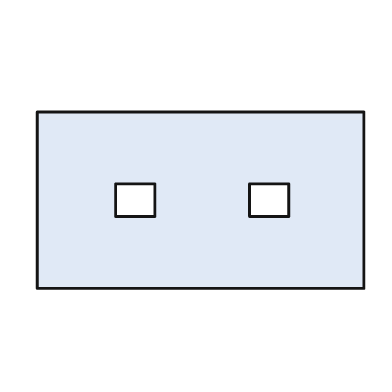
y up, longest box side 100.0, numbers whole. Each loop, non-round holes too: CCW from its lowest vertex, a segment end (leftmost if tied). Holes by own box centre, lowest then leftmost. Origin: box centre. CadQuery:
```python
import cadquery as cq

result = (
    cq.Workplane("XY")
    .moveTo(-50.0, -27.0)
    .lineTo(50.0, -27.0)
    .lineTo(50.0, 27.0)
    .lineTo(-50.0, 27.0)
    .close()
    .moveTo(-26.0, -5.0)
    .lineTo(-14.0, -5.0)
    .lineTo(-14.0, 5.0)
    .lineTo(-26.0, 5.0)
    .close()
    .moveTo(15.0, -5.0)
    .lineTo(27.0, -5.0)
    .lineTo(27.0, 5.0)
    .lineTo(15.0, 5.0)
    .close()
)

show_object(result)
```